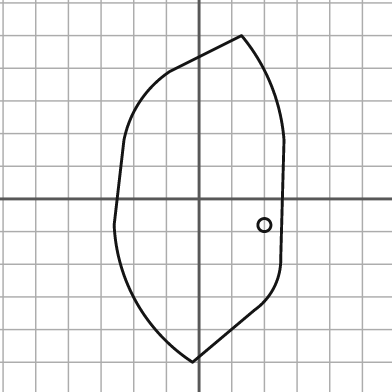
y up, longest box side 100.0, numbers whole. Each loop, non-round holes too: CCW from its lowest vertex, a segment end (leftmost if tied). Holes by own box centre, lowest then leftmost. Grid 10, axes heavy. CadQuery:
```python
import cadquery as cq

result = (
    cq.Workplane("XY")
    .moveTo(-2.0, -50.0)
    .lineTo(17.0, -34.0)
    .threePointArc((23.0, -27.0), (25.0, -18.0))
    .lineTo(26.0, 18.0)
    .threePointArc((22.0, 35.0), (13.0, 50.0))
    .lineTo(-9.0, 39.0)
    .threePointArc((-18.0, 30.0), (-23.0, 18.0))
    .lineTo(-26.0, -8.0)
    .threePointArc((-19.0, -32.0), (-2.0, -50.0))
    .close()
    .moveTo(20.0, -8.0)
    .circle(2.0)
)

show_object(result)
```